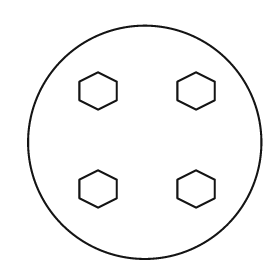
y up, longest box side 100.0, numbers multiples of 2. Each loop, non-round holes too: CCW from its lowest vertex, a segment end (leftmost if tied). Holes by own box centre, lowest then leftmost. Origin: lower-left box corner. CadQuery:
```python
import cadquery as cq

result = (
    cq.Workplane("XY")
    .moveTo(50.0, 50.0)
    .circle(50.0)
    .moveTo(30.0, 22.0)
    .lineTo(38.0, 26.0)
    .lineTo(38.0, 34.0)
    .lineTo(30.0, 38.0)
    .lineTo(22.0, 34.0)
    .lineTo(22.0, 26.0)
    .close()
    .moveTo(72.0, 22.0)
    .lineTo(80.0, 26.0)
    .lineTo(80.0, 34.0)
    .lineTo(72.0, 38.0)
    .lineTo(64.0, 34.0)
    .lineTo(64.0, 26.0)
    .close()
    .moveTo(30.0, 64.0)
    .lineTo(38.0, 68.0)
    .lineTo(38.0, 76.0)
    .lineTo(30.0, 80.0)
    .lineTo(22.0, 76.0)
    .lineTo(22.0, 68.0)
    .close()
    .moveTo(72.0, 64.0)
    .lineTo(80.0, 68.0)
    .lineTo(80.0, 76.0)
    .lineTo(72.0, 80.0)
    .lineTo(64.0, 76.0)
    .lineTo(64.0, 68.0)
    .close()
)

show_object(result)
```